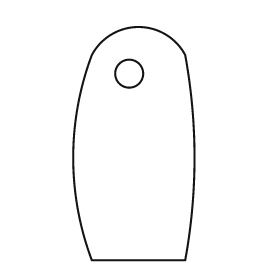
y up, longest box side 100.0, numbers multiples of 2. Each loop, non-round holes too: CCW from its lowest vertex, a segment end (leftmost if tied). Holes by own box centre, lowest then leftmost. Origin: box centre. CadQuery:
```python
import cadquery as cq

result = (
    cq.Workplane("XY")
    .moveTo(-18.0, -50.0)
    .lineTo(22.0, -50.0)
    .threePointArc((26.0, -6.0), (22.0, 38.0))
    .threePointArc((2.0, 50.0), (-18.0, 38.0))
    .threePointArc((-26.0, -6.0), (-18.0, -50.0))
    .close()
    .moveTo(-2.0, 30.0)
    .circle(6.0)
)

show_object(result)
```